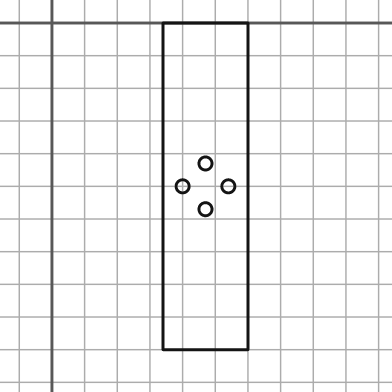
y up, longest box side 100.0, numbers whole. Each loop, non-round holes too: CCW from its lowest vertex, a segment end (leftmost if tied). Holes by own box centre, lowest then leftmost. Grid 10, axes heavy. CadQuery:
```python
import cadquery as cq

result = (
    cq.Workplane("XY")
    .moveTo(34.0, -100.0)
    .lineTo(60.0, -100.0)
    .lineTo(60.0, 0.0)
    .lineTo(34.0, 0.0)
    .close()
    .moveTo(47.0, -57.0)
    .circle(2.0)
    .moveTo(40.0, -50.0)
    .circle(2.0)
    .moveTo(54.0, -50.0)
    .circle(2.0)
    .moveTo(47.0, -43.0)
    .circle(2.0)
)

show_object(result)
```